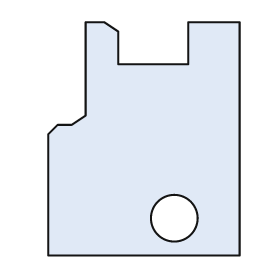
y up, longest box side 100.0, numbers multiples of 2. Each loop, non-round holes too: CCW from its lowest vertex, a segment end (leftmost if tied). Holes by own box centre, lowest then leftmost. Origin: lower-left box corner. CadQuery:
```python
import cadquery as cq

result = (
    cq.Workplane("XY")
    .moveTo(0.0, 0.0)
    .lineTo(82.0, 0.0)
    .lineTo(82.0, 100.0)
    .lineTo(60.0, 100.0)
    .lineTo(60.0, 82.0)
    .lineTo(30.0, 82.0)
    .lineTo(30.0, 96.0)
    .lineTo(24.0, 100.0)
    .lineTo(16.0, 100.0)
    .lineTo(16.0, 60.0)
    .lineTo(10.0, 56.0)
    .lineTo(4.0, 56.0)
    .lineTo(0.0, 52.0)
    .close()
    .moveTo(54.0, 16.0)
    .circle(10.0)
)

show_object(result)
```